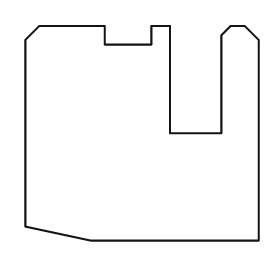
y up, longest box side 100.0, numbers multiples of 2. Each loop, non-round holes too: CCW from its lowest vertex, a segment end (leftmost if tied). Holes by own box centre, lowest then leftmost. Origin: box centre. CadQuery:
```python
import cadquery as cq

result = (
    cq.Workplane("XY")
    .moveTo(-22.0, -46.0)
    .lineTo(50.0, -46.0)
    .lineTo(50.0, 40.0)
    .lineTo(44.0, 46.0)
    .lineTo(38.0, 46.0)
    .lineTo(34.0, 42.0)
    .lineTo(34.0, 0.0)
    .lineTo(12.0, 0.0)
    .lineTo(12.0, 46.0)
    .lineTo(4.0, 46.0)
    .lineTo(4.0, 38.0)
    .lineTo(-16.0, 38.0)
    .lineTo(-16.0, 46.0)
    .lineTo(-44.0, 46.0)
    .lineTo(-50.0, 40.0)
    .lineTo(-50.0, -40.0)
    .close()
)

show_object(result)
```